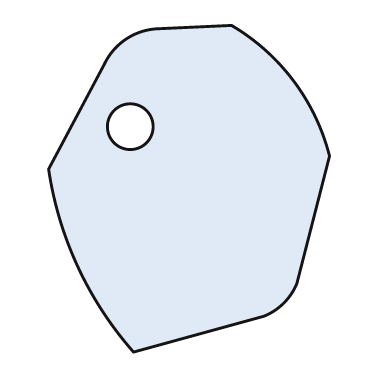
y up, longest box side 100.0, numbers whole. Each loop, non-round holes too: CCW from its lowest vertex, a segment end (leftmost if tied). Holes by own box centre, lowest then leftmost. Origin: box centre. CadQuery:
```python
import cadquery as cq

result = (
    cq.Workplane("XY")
    .moveTo(-17.0, -50.0)
    .lineTo(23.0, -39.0)
    .threePointArc((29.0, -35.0), (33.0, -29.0))
    .lineTo(43.0, 10.0)
    .threePointArc((32.0, 33.0), (13.0, 50.0))
    .lineTo(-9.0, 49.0)
    .threePointArc((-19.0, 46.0), (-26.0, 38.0))
    .lineTo(-43.0, 6.0)
    .threePointArc((-34.0, -24.0), (-17.0, -50.0))
    .close()
    .moveTo(-18.0, 19.0)
    .circle(7.0)
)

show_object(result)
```